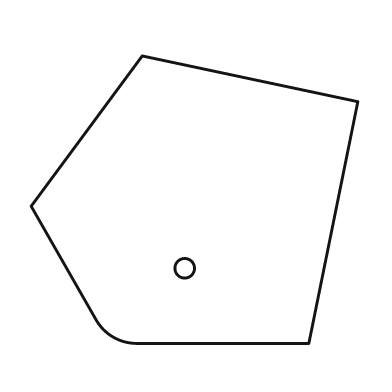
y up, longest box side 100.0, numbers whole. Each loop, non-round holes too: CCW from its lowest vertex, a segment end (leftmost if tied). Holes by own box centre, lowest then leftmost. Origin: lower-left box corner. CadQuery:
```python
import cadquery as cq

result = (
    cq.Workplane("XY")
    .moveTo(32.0, 0.0)
    .lineTo(85.0, 0.0)
    .lineTo(100.0, 74.0)
    .lineTo(34.0, 88.0)
    .lineTo(0.0, 42.0)
    .lineTo(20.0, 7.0)
    .threePointArc((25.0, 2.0), (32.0, 0.0))
    .close()
    .moveTo(47.0, 23.0)
    .circle(3.0)
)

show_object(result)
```